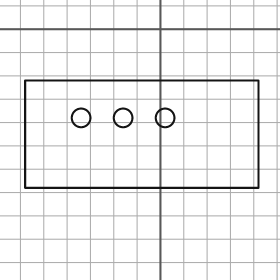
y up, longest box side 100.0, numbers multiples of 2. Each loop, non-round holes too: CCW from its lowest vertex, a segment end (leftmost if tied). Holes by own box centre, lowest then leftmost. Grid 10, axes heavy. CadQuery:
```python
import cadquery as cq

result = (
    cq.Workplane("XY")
    .moveTo(-58.0, -68.0)
    .lineTo(42.0, -68.0)
    .lineTo(42.0, -22.0)
    .lineTo(-58.0, -22.0)
    .close()
    .moveTo(-34.0, -38.0)
    .circle(4.0)
    .moveTo(-16.0, -38.0)
    .circle(4.0)
    .moveTo(2.0, -38.0)
    .circle(4.0)
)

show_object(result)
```